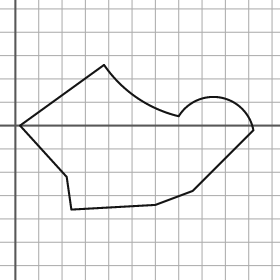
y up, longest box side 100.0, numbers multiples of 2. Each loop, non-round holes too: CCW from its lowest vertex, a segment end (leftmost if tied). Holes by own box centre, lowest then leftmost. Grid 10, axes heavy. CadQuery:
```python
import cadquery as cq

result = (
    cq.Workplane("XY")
    .moveTo(24.0, -36.0)
    .lineTo(60.0, -34.0)
    .lineTo(76.0, -28.0)
    .lineTo(102.0, -2.0)
    .threePointArc((88.0, 12.0), (70.0, 4.0))
    .threePointArc((52.0, 12.0), (38.0, 26.0))
    .lineTo(2.0, 0.0)
    .lineTo(22.0, -22.0)
    .close()
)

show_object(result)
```